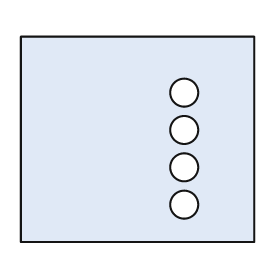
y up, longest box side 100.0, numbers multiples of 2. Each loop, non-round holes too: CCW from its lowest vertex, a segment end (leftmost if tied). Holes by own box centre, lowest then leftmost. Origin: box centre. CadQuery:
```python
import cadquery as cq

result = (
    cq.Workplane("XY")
    .moveTo(-50.0, -44.0)
    .lineTo(50.0, -44.0)
    .lineTo(50.0, 44.0)
    .lineTo(-50.0, 44.0)
    .close()
    .moveTo(20.0, -28.0)
    .circle(6.0)
    .moveTo(20.0, -12.0)
    .circle(6.0)
    .moveTo(20.0, 4.0)
    .circle(6.0)
    .moveTo(20.0, 20.0)
    .circle(6.0)
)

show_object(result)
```